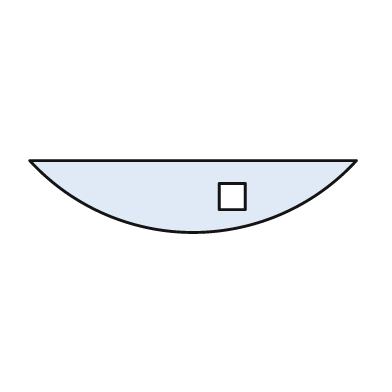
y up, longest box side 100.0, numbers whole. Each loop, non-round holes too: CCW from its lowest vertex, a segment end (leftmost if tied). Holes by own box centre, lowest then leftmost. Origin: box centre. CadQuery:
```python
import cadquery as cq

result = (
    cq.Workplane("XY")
    .moveTo(-50.0, 11.0)
    .threePointArc((0.0, -11.0), (50.0, 11.0))
    .close()
    .moveTo(8.0, -4.0)
    .lineTo(16.0, -4.0)
    .lineTo(16.0, 4.0)
    .lineTo(8.0, 4.0)
    .close()
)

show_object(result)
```